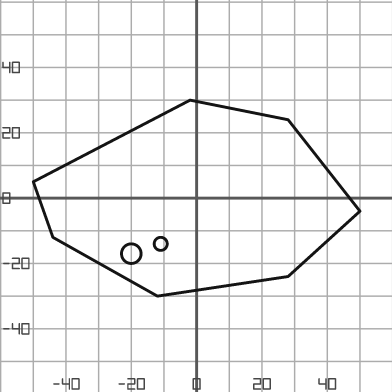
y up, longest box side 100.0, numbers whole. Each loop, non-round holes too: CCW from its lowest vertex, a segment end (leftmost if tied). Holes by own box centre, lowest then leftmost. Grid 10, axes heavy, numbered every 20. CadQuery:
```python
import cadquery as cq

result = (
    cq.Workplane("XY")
    .moveTo(-12.0, -30.0)
    .lineTo(28.0, -24.0)
    .lineTo(50.0, -4.0)
    .lineTo(28.0, 24.0)
    .lineTo(-2.0, 30.0)
    .lineTo(-50.0, 5.0)
    .lineTo(-44.0, -12.0)
    .close()
    .moveTo(-20.0, -17.0)
    .circle(3.0)
    .moveTo(-11.0, -14.0)
    .circle(2.0)
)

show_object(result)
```